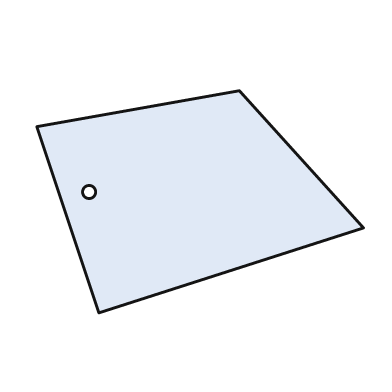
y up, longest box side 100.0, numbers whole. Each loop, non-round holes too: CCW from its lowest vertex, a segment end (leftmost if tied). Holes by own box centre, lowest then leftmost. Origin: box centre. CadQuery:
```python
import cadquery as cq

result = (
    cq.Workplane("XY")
    .moveTo(-31.0, -34.0)
    .lineTo(50.0, -8.0)
    .lineTo(12.0, 34.0)
    .lineTo(-50.0, 23.0)
    .close()
    .moveTo(-34.0, 3.0)
    .circle(2.0)
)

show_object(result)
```